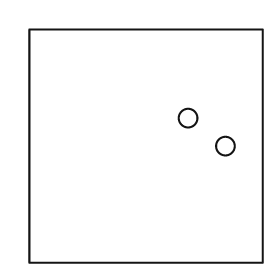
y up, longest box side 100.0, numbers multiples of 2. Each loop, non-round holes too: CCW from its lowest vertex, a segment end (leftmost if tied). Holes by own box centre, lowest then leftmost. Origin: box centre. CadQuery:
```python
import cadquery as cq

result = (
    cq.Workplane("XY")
    .moveTo(-50.0, -50.0)
    .lineTo(50.0, -50.0)
    .lineTo(50.0, 50.0)
    .lineTo(-50.0, 50.0)
    .close()
    .moveTo(34.0, 0.0)
    .circle(4.0)
    .moveTo(18.0, 12.0)
    .circle(4.0)
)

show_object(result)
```